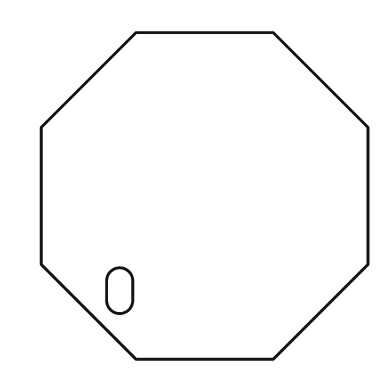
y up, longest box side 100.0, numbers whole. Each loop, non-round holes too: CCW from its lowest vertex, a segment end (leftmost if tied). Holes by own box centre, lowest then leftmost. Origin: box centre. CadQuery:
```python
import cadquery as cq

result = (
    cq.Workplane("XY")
    .moveTo(-21.0, -50.0)
    .lineTo(21.0, -50.0)
    .lineTo(50.0, -21.0)
    .lineTo(50.0, 21.0)
    .lineTo(21.0, 50.0)
    .lineTo(-21.0, 50.0)
    .lineTo(-50.0, 21.0)
    .lineTo(-50.0, -21.0)
    .close()
    .moveTo(-30.0, -32.0)
    .threePointArc((-26.0, -36.0), (-22.0, -32.0))
    .lineTo(-22.0, -26.0)
    .threePointArc((-26.0, -22.0), (-30.0, -26.0))
    .close()
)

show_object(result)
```